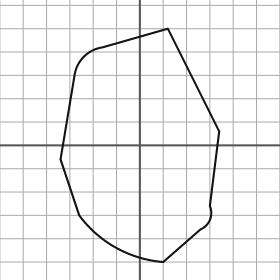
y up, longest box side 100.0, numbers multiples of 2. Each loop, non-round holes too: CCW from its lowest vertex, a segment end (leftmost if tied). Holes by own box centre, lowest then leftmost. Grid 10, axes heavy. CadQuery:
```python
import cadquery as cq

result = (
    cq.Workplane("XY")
    .moveTo(10.0, -50.0)
    .lineTo(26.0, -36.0)
    .threePointArc((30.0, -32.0), (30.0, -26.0))
    .lineTo(34.0, 6.0)
    .lineTo(12.0, 50.0)
    .lineTo(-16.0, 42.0)
    .threePointArc((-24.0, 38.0), (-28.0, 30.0))
    .lineTo(-34.0, -6.0)
    .lineTo(-26.0, -30.0)
    .threePointArc((-10.0, -44.0), (10.0, -50.0))
    .close()
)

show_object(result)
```